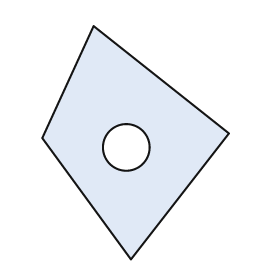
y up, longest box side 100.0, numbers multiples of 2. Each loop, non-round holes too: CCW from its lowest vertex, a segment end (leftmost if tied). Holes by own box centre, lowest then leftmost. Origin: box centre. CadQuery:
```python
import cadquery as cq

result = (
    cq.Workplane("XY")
    .moveTo(-2.0, -50.0)
    .lineTo(40.0, 4.0)
    .lineTo(-18.0, 50.0)
    .lineTo(-40.0, 2.0)
    .close()
    .moveTo(-4.0, -2.0)
    .circle(10.0)
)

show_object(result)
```